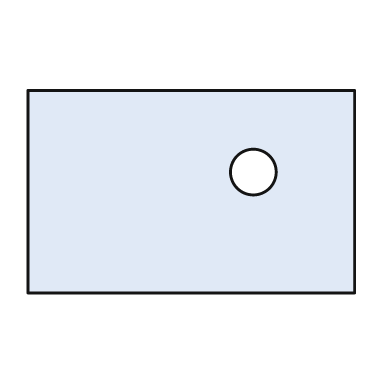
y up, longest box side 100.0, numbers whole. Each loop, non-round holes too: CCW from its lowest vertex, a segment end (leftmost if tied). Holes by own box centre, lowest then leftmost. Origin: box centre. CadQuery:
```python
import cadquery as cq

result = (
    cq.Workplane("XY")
    .moveTo(-50.0, -31.0)
    .lineTo(50.0, -31.0)
    .lineTo(50.0, 31.0)
    .lineTo(-50.0, 31.0)
    .close()
    .moveTo(19.0, 6.0)
    .circle(7.0)
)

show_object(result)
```